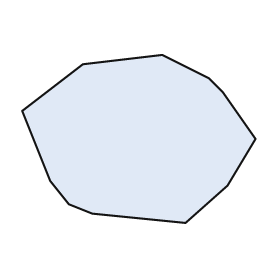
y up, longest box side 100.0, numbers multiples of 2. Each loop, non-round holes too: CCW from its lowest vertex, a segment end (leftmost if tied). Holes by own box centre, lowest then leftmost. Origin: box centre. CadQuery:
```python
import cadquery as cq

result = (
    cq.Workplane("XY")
    .moveTo(20.0, -36.0)
    .lineTo(38.0, -20.0)
    .lineTo(50.0, 0.0)
    .lineTo(36.0, 20.0)
    .lineTo(30.0, 26.0)
    .lineTo(10.0, 36.0)
    .lineTo(-24.0, 32.0)
    .lineTo(-50.0, 12.0)
    .lineTo(-38.0, -18.0)
    .lineTo(-30.0, -28.0)
    .lineTo(-20.0, -32.0)
    .close()
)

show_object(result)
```